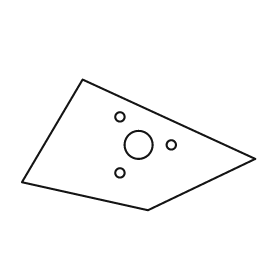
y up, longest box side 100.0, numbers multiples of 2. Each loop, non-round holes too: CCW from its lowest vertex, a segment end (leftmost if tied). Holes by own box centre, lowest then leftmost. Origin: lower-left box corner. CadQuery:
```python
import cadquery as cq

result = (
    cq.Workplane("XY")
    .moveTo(54.0, 0.0)
    .lineTo(100.0, 22.0)
    .lineTo(26.0, 56.0)
    .lineTo(0.0, 12.0)
    .close()
    .moveTo(42.0, 16.0)
    .circle(2.0)
    .moveTo(50.0, 28.0)
    .circle(6.0)
    .moveTo(64.0, 28.0)
    .circle(2.0)
    .moveTo(42.0, 40.0)
    .circle(2.0)
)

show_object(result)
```